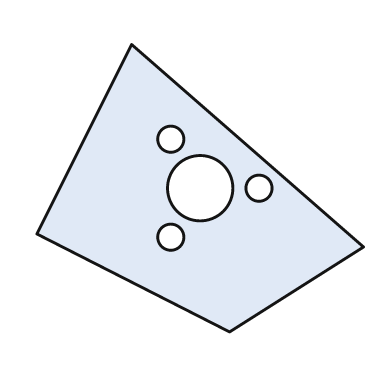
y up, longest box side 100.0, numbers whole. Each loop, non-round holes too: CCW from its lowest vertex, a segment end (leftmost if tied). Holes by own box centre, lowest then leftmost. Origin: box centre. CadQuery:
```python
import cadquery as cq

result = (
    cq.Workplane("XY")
    .moveTo(9.0, -44.0)
    .lineTo(50.0, -18.0)
    .lineTo(-21.0, 44.0)
    .lineTo(-50.0, -14.0)
    .close()
    .moveTo(-9.0, -15.0)
    .circle(4.0)
    .moveTo(0.0, 0.0)
    .circle(10.0)
    .moveTo(18.0, 0.0)
    .circle(4.0)
    .moveTo(-9.0, 15.0)
    .circle(4.0)
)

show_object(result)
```